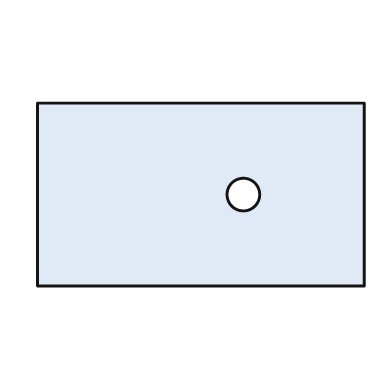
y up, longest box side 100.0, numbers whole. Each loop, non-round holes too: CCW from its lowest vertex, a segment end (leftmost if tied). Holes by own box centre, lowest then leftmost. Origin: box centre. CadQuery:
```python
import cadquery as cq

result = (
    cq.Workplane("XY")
    .moveTo(-50.0, -28.0)
    .lineTo(50.0, -28.0)
    .lineTo(50.0, 28.0)
    .lineTo(-50.0, 28.0)
    .close()
    .moveTo(13.0, 0.0)
    .circle(5.0)
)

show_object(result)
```